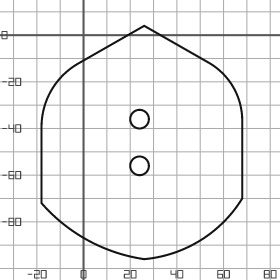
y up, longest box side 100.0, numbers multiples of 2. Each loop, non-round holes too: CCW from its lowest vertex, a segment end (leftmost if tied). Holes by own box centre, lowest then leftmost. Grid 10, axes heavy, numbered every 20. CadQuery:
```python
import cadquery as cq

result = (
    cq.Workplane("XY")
    .moveTo(26.0, -96.0)
    .threePointArc((50.0, -88.0), (68.0, -70.0))
    .lineTo(68.0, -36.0)
    .threePointArc((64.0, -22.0), (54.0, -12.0))
    .lineTo(26.0, 4.0)
    .lineTo(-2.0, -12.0)
    .threePointArc((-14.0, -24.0), (-18.0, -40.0))
    .lineTo(-18.0, -72.0)
    .threePointArc((2.0, -88.0), (26.0, -96.0))
    .close()
    .moveTo(24.0, -56.0)
    .circle(4.0)
    .moveTo(24.0, -36.0)
    .circle(4.0)
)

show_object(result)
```